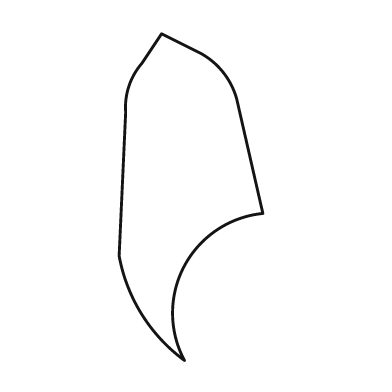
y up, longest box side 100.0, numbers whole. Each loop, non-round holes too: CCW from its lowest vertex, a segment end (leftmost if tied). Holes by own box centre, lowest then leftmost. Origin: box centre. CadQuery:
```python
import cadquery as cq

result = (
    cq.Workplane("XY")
    .moveTo(-2.0, -50.0)
    .threePointArc((-2.0, -21.0), (22.0, -5.0))
    .lineTo(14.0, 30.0)
    .threePointArc((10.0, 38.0), (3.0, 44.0))
    .lineTo(-9.0, 50.0)
    .lineTo(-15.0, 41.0)
    .threePointArc((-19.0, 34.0), (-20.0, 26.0))
    .lineTo(-22.0, -18.0)
    .threePointArc((-15.0, -36.0), (-2.0, -50.0))
    .close()
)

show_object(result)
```